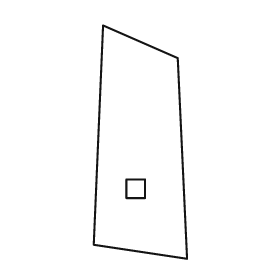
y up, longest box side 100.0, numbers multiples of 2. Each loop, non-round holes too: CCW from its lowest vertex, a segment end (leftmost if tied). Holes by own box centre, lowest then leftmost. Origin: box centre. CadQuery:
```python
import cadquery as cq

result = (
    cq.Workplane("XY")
    .moveTo(20.0, -50.0)
    .lineTo(16.0, 36.0)
    .lineTo(-16.0, 50.0)
    .lineTo(-20.0, -44.0)
    .close()
    .moveTo(-6.0, -24.0)
    .lineTo(2.0, -24.0)
    .lineTo(2.0, -16.0)
    .lineTo(-6.0, -16.0)
    .close()
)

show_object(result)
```